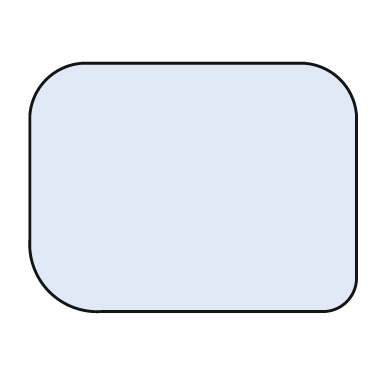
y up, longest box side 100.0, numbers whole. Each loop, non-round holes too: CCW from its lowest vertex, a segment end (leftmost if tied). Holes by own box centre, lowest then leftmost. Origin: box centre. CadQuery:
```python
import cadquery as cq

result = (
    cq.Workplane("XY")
    .moveTo(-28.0, -38.0)
    .lineTo(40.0, -38.0)
    .threePointArc((47.0, -35.0), (50.0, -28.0))
    .lineTo(50.0, 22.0)
    .threePointArc((45.0, 33.0), (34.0, 38.0))
    .lineTo(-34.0, 38.0)
    .threePointArc((-45.0, 33.0), (-50.0, 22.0))
    .lineTo(-50.0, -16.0)
    .threePointArc((-44.0, -32.0), (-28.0, -38.0))
    .close()
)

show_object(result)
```